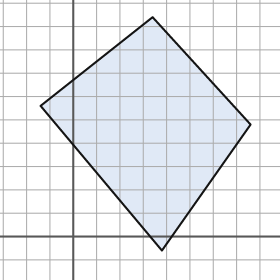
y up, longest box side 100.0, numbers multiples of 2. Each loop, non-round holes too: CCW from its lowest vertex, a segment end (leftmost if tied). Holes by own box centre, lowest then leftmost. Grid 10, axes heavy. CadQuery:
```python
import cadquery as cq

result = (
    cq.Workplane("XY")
    .moveTo(38.0, -6.0)
    .lineTo(76.0, 48.0)
    .lineTo(34.0, 94.0)
    .lineTo(-14.0, 56.0)
    .close()
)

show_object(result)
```